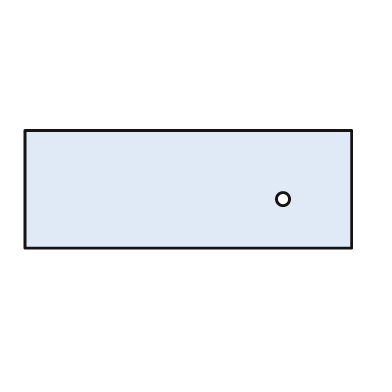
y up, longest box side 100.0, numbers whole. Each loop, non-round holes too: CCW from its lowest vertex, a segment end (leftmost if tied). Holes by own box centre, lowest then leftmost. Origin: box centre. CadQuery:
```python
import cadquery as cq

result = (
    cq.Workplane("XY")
    .moveTo(-50.0, -18.0)
    .lineTo(50.0, -18.0)
    .lineTo(50.0, 18.0)
    .lineTo(-50.0, 18.0)
    .close()
    .moveTo(29.0, -3.0)
    .circle(2.0)
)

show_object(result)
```